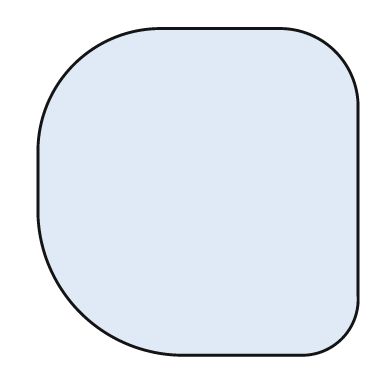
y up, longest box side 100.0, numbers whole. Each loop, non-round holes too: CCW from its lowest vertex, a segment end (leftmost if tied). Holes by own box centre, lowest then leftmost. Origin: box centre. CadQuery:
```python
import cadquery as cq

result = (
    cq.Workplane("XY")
    .moveTo(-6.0, -50.0)
    .lineTo(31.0, -50.0)
    .threePointArc((44.0, -45.0), (49.0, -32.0))
    .lineTo(49.0, 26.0)
    .threePointArc((42.0, 43.0), (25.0, 50.0))
    .lineTo(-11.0, 50.0)
    .threePointArc((-38.0, 39.0), (-49.0, 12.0))
    .lineTo(-49.0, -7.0)
    .threePointArc((-36.0, -37.0), (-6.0, -50.0))
    .close()
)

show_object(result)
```